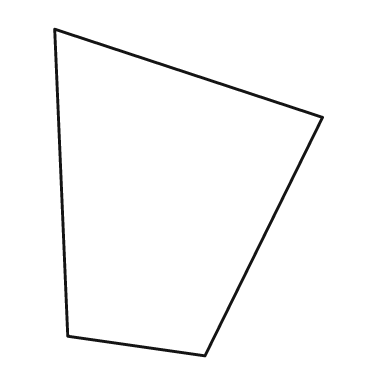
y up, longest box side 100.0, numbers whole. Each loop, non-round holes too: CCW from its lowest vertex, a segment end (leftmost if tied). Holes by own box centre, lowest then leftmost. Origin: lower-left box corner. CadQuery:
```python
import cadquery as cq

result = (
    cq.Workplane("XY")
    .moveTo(46.0, 0.0)
    .lineTo(82.0, 73.0)
    .lineTo(0.0, 100.0)
    .lineTo(4.0, 6.0)
    .close()
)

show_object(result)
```